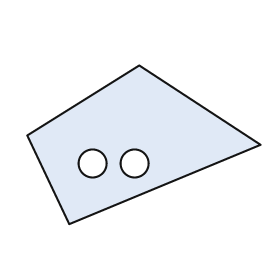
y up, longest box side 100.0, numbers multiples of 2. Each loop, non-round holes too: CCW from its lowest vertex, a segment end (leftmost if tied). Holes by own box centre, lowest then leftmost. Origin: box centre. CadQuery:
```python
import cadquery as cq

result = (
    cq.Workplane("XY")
    .moveTo(-32.0, -34.0)
    .lineTo(50.0, 0.0)
    .lineTo(-2.0, 34.0)
    .lineTo(-50.0, 4.0)
    .close()
    .moveTo(-22.0, -8.0)
    .circle(6.0)
    .moveTo(-4.0, -8.0)
    .circle(6.0)
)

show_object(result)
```